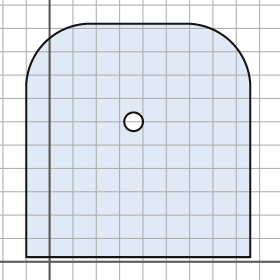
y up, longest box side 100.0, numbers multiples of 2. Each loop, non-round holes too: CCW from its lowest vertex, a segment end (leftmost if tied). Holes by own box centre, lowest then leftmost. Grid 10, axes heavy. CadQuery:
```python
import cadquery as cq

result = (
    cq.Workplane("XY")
    .moveTo(-10.0, 2.0)
    .lineTo(86.0, 2.0)
    .lineTo(86.0, 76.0)
    .threePointArc((78.0, 94.0), (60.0, 102.0))
    .lineTo(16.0, 102.0)
    .threePointArc((-2.0, 94.0), (-10.0, 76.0))
    .close()
    .moveTo(36.0, 60.0)
    .circle(4.0)
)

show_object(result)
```